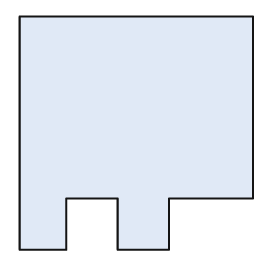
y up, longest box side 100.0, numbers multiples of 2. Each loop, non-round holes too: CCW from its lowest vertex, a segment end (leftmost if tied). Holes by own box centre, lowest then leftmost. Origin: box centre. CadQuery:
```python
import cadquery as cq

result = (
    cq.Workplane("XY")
    .moveTo(-50.0, -50.0)
    .lineTo(-30.0, -50.0)
    .lineTo(-30.0, -28.0)
    .lineTo(-8.0, -28.0)
    .lineTo(-8.0, -50.0)
    .lineTo(14.0, -50.0)
    .lineTo(14.0, -28.0)
    .lineTo(50.0, -28.0)
    .lineTo(50.0, 50.0)
    .lineTo(-50.0, 50.0)
    .close()
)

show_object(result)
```